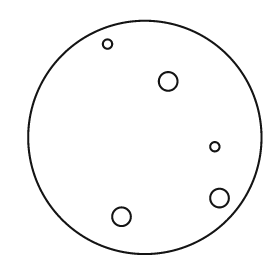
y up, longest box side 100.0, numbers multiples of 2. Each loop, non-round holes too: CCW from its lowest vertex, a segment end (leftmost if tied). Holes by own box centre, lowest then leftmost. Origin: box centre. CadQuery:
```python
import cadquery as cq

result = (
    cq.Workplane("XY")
    .moveTo(0.0, 0.0)
    .circle(50.0)
    .moveTo(-10.0, -34.0)
    .circle(4.0)
    .moveTo(32.0, -26.0)
    .circle(4.0)
    .moveTo(30.0, -4.0)
    .circle(2.0)
    .moveTo(10.0, 24.0)
    .circle(4.0)
    .moveTo(-16.0, 40.0)
    .circle(2.0)
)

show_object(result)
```